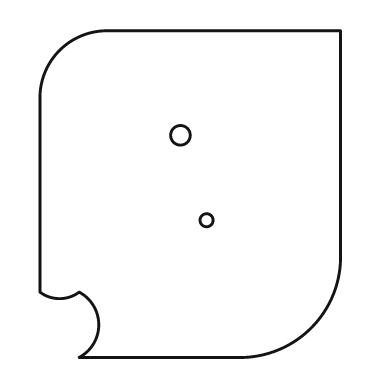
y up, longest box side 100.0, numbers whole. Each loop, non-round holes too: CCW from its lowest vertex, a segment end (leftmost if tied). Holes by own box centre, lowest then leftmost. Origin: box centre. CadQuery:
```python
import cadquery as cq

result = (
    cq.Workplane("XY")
    .moveTo(-34.0, -50.0)
    .lineTo(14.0, -50.0)
    .threePointArc((37.0, -41.0), (46.0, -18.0))
    .lineTo(46.0, 50.0)
    .lineTo(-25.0, 50.0)
    .threePointArc((-40.0, 44.0), (-46.0, 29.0))
    .lineTo(-46.0, -30.0)
    .threePointArc((-40.0, -32.0), (-34.0, -30.0))
    .threePointArc((-28.0, -40.0), (-34.0, -50.0))
    .close()
    .moveTo(5.0, -8.0)
    .circle(2.0)
    .moveTo(-3.0, 18.0)
    .circle(3.0)
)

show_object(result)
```